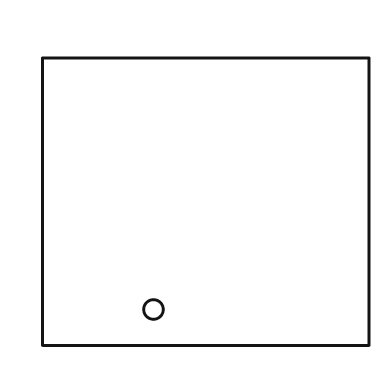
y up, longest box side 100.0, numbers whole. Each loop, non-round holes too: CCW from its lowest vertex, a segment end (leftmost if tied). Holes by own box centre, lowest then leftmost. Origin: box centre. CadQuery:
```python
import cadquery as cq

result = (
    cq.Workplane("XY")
    .moveTo(-50.0, -44.0)
    .lineTo(50.0, -44.0)
    .lineTo(50.0, 44.0)
    .lineTo(-50.0, 44.0)
    .close()
    .moveTo(-16.0, -33.0)
    .circle(3.0)
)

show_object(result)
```